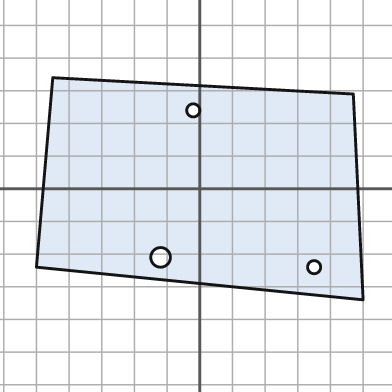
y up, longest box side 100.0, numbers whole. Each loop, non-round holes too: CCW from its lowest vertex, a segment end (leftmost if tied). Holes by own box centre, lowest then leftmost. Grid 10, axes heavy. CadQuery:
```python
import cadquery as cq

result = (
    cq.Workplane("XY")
    .moveTo(50.0, -34.0)
    .lineTo(47.0, 29.0)
    .lineTo(-45.0, 34.0)
    .lineTo(-50.0, -24.0)
    .close()
    .moveTo(35.0, -24.0)
    .circle(2.0)
    .moveTo(-12.0, -21.0)
    .circle(3.0)
    .moveTo(-2.0, 24.0)
    .circle(2.0)
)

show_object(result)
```